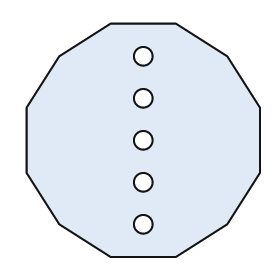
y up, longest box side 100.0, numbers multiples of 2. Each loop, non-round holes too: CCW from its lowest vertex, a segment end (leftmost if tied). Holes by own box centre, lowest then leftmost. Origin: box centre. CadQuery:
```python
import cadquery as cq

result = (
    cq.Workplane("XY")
    .moveTo(-14.0, -50.0)
    .lineTo(14.0, -50.0)
    .lineTo(36.0, -36.0)
    .lineTo(50.0, -14.0)
    .lineTo(50.0, 14.0)
    .lineTo(36.0, 36.0)
    .lineTo(14.0, 50.0)
    .lineTo(-14.0, 50.0)
    .lineTo(-36.0, 36.0)
    .lineTo(-50.0, 14.0)
    .lineTo(-50.0, -14.0)
    .lineTo(-36.0, -36.0)
    .close()
    .moveTo(0.0, -36.0)
    .circle(4.0)
    .moveTo(0.0, -18.0)
    .circle(4.0)
    .moveTo(0.0, 0.0)
    .circle(4.0)
    .moveTo(0.0, 18.0)
    .circle(4.0)
    .moveTo(0.0, 36.0)
    .circle(4.0)
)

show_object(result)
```